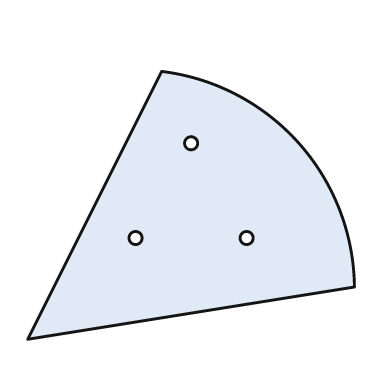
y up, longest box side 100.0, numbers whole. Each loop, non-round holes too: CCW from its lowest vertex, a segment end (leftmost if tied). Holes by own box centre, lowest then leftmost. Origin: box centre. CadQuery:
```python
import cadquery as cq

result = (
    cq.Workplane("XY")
    .moveTo(-50.0, -41.0)
    .lineTo(50.0, -25.0)
    .threePointArc((33.0, 19.0), (-9.0, 41.0))
    .close()
    .moveTo(-17.0, -10.0)
    .circle(2.0)
    .moveTo(17.0, -10.0)
    .circle(2.0)
    .moveTo(0.0, 19.0)
    .circle(2.0)
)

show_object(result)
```